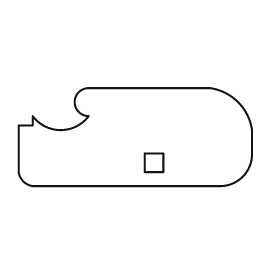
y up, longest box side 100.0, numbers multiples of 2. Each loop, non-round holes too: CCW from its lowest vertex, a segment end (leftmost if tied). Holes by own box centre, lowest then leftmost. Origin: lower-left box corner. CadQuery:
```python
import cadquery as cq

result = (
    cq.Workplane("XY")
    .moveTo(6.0, 0.0)
    .lineTo(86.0, 0.0)
    .threePointArc((96.0, 4.0), (100.0, 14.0))
    .lineTo(100.0, 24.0)
    .threePointArc((94.0, 36.0), (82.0, 42.0))
    .lineTo(30.0, 42.0)
    .threePointArc((24.0, 36.0), (30.0, 30.0))
    .threePointArc((18.0, 24.0), (6.0, 30.0))
    .lineTo(6.0, 26.0)
    .lineTo(0.0, 26.0)
    .lineTo(0.0, 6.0)
    .threePointArc((2.0, 2.0), (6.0, 0.0))
    .close()
    .moveTo(54.0, 6.0)
    .lineTo(62.0, 6.0)
    .lineTo(62.0, 14.0)
    .lineTo(54.0, 14.0)
    .close()
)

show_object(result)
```